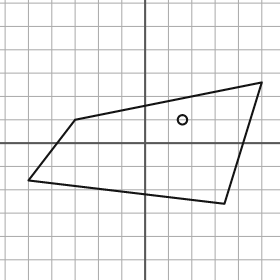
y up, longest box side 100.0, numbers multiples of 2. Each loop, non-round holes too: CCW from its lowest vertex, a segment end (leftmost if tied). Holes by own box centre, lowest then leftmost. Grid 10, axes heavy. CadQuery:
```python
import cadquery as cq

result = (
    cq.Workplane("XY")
    .moveTo(34.0, -26.0)
    .lineTo(50.0, 26.0)
    .lineTo(-30.0, 10.0)
    .lineTo(-50.0, -16.0)
    .close()
    .moveTo(16.0, 10.0)
    .circle(2.0)
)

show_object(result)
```